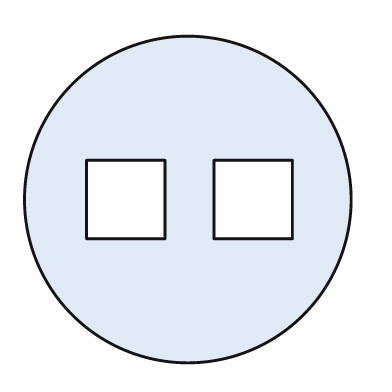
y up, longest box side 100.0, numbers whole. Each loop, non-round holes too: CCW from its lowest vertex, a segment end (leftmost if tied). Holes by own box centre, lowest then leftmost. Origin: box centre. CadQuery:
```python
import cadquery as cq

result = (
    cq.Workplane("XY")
    .moveTo(0.0, 0.0)
    .circle(50.0)
    .moveTo(-31.0, -12.0)
    .lineTo(-7.0, -12.0)
    .lineTo(-7.0, 12.0)
    .lineTo(-31.0, 12.0)
    .close()
    .moveTo(8.0, -12.0)
    .lineTo(32.0, -12.0)
    .lineTo(32.0, 12.0)
    .lineTo(8.0, 12.0)
    .close()
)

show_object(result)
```